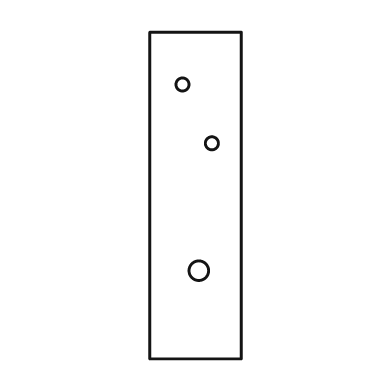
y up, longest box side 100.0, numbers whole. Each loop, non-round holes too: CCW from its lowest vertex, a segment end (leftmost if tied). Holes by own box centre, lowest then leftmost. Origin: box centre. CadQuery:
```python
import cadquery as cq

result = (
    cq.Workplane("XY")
    .moveTo(-14.0, -50.0)
    .lineTo(14.0, -50.0)
    .lineTo(14.0, 50.0)
    .lineTo(-14.0, 50.0)
    .close()
    .moveTo(1.0, -23.0)
    .circle(3.0)
    .moveTo(5.0, 16.0)
    .circle(2.0)
    .moveTo(-4.0, 34.0)
    .circle(2.0)
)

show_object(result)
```